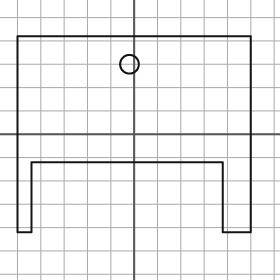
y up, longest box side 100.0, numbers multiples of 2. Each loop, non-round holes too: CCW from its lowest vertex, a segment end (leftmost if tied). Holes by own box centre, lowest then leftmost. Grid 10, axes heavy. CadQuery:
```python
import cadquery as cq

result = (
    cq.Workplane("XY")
    .moveTo(-50.0, -42.0)
    .lineTo(-44.0, -42.0)
    .lineTo(-44.0, -12.0)
    .lineTo(38.0, -12.0)
    .lineTo(38.0, -42.0)
    .lineTo(50.0, -42.0)
    .lineTo(50.0, 42.0)
    .lineTo(-50.0, 42.0)
    .close()
    .moveTo(-2.0, 30.0)
    .circle(4.0)
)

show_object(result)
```